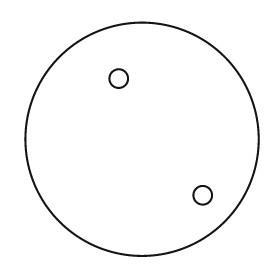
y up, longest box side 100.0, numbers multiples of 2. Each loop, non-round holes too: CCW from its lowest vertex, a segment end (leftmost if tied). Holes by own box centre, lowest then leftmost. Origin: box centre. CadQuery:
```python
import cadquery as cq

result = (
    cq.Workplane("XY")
    .moveTo(0.0, 0.0)
    .circle(50.0)
    .moveTo(26.0, -24.0)
    .circle(4.0)
    .moveTo(-10.0, 26.0)
    .circle(4.0)
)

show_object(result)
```